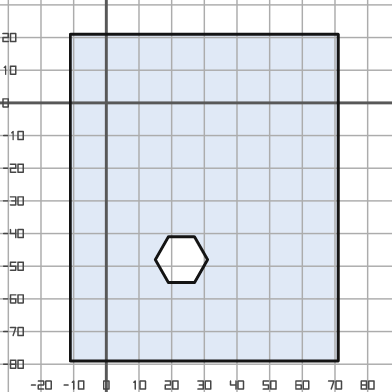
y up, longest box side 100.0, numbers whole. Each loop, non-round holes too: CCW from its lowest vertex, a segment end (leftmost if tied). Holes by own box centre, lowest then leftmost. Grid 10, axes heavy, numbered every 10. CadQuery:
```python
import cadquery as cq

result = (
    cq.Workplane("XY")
    .moveTo(-11.0, -79.0)
    .lineTo(71.0, -79.0)
    .lineTo(71.0, 21.0)
    .lineTo(-11.0, 21.0)
    .close()
    .moveTo(19.0, -55.0)
    .lineTo(27.0, -55.0)
    .lineTo(31.0, -48.0)
    .lineTo(27.0, -41.0)
    .lineTo(19.0, -41.0)
    .lineTo(15.0, -48.0)
    .close()
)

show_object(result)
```